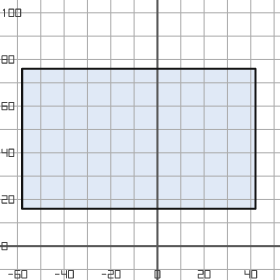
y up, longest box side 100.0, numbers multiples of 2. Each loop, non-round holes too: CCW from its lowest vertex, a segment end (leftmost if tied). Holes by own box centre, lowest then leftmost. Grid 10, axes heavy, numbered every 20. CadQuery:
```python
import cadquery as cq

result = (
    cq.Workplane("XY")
    .moveTo(-58.0, 16.0)
    .lineTo(42.0, 16.0)
    .lineTo(42.0, 76.0)
    .lineTo(-58.0, 76.0)
    .close()
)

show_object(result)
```